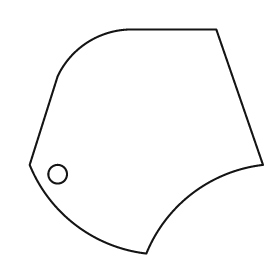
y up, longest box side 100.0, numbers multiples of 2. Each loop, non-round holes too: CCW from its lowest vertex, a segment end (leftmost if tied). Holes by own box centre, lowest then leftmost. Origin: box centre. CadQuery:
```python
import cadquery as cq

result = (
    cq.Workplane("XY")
    .moveTo(0.0, -48.0)
    .threePointArc((20.0, -22.0), (50.0, -10.0))
    .lineTo(30.0, 48.0)
    .lineTo(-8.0, 48.0)
    .threePointArc((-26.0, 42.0), (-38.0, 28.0))
    .lineTo(-50.0, -10.0)
    .threePointArc((-30.0, -36.0), (0.0, -48.0))
    .close()
    .moveTo(-38.0, -14.0)
    .circle(4.0)
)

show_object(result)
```